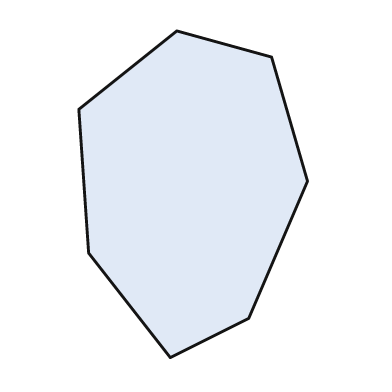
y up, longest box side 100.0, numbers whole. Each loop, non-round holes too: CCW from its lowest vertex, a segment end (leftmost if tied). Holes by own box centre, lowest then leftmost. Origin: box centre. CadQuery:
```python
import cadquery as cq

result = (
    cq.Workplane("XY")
    .moveTo(-7.0, -50.0)
    .lineTo(17.0, -38.0)
    .lineTo(35.0, 4.0)
    .lineTo(24.0, 42.0)
    .lineTo(-5.0, 50.0)
    .lineTo(-35.0, 26.0)
    .lineTo(-32.0, -18.0)
    .close()
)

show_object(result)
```